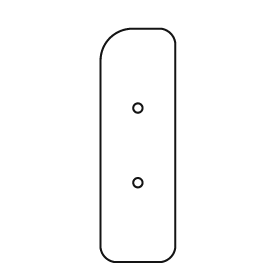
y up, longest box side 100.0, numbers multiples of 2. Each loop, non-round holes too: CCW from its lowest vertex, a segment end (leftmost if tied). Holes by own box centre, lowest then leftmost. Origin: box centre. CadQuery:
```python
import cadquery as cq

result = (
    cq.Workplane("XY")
    .moveTo(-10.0, -50.0)
    .lineTo(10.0, -50.0)
    .threePointArc((14.0, -48.0), (16.0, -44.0))
    .lineTo(16.0, 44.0)
    .threePointArc((14.0, 48.0), (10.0, 50.0))
    .lineTo(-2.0, 50.0)
    .threePointArc((-12.0, 46.0), (-16.0, 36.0))
    .lineTo(-16.0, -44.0)
    .threePointArc((-14.0, -48.0), (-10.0, -50.0))
    .close()
    .moveTo(0.0, -16.0)
    .circle(2.0)
    .moveTo(0.0, 16.0)
    .circle(2.0)
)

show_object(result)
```